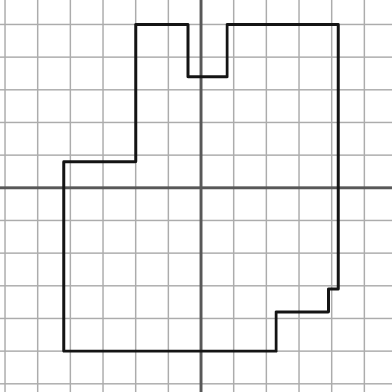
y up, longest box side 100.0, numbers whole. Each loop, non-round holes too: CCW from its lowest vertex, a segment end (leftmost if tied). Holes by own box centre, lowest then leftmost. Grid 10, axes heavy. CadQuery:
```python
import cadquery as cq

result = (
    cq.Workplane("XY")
    .moveTo(-42.0, -50.0)
    .lineTo(23.0, -50.0)
    .lineTo(23.0, -38.0)
    .lineTo(39.0, -38.0)
    .lineTo(39.0, -31.0)
    .lineTo(42.0, -31.0)
    .lineTo(42.0, 50.0)
    .lineTo(8.0, 50.0)
    .lineTo(8.0, 34.0)
    .lineTo(-4.0, 34.0)
    .lineTo(-4.0, 50.0)
    .lineTo(-20.0, 50.0)
    .lineTo(-20.0, 8.0)
    .lineTo(-42.0, 8.0)
    .close()
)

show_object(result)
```